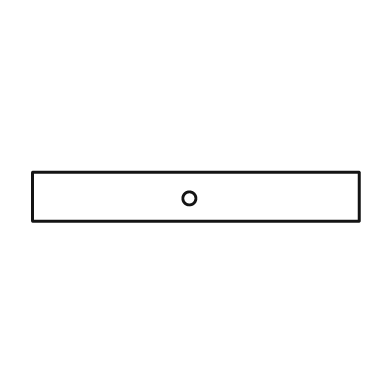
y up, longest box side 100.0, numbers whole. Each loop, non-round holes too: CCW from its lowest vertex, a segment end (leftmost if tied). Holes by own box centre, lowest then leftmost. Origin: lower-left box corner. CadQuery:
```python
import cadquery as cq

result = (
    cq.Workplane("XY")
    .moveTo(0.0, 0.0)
    .lineTo(100.0, 0.0)
    .lineTo(100.0, 15.0)
    .lineTo(0.0, 15.0)
    .close()
    .moveTo(48.0, 7.0)
    .circle(2.0)
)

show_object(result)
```